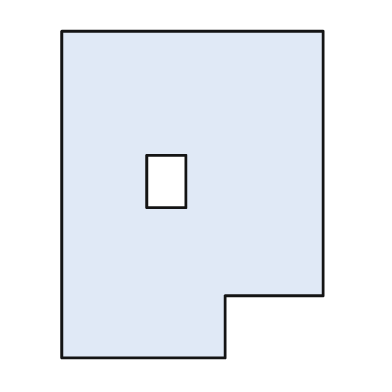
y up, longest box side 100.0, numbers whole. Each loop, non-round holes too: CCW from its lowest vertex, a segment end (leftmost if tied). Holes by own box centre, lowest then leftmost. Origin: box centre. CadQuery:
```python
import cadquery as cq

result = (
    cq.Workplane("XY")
    .moveTo(-40.0, -50.0)
    .lineTo(10.0, -50.0)
    .lineTo(10.0, -31.0)
    .lineTo(40.0, -31.0)
    .lineTo(40.0, 50.0)
    .lineTo(-40.0, 50.0)
    .close()
    .moveTo(-14.0, -4.0)
    .lineTo(-2.0, -4.0)
    .lineTo(-2.0, 12.0)
    .lineTo(-14.0, 12.0)
    .close()
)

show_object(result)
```